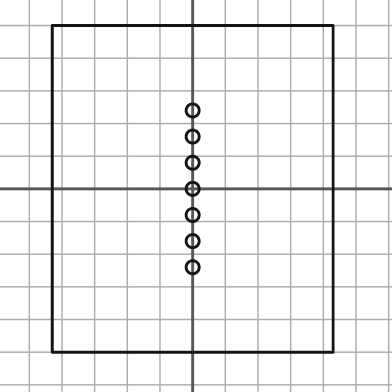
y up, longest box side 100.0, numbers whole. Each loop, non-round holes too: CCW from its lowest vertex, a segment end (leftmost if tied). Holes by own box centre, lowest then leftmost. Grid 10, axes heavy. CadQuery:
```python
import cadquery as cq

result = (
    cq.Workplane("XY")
    .moveTo(-43.0, -50.0)
    .lineTo(43.0, -50.0)
    .lineTo(43.0, 50.0)
    .lineTo(-43.0, 50.0)
    .close()
    .moveTo(0.0, -24.0)
    .circle(2.0)
    .moveTo(0.0, -16.0)
    .circle(2.0)
    .moveTo(0.0, -8.0)
    .circle(2.0)
    .moveTo(0.0, 0.0)
    .circle(2.0)
    .moveTo(0.0, 8.0)
    .circle(2.0)
    .moveTo(0.0, 16.0)
    .circle(2.0)
    .moveTo(0.0, 24.0)
    .circle(2.0)
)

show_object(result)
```